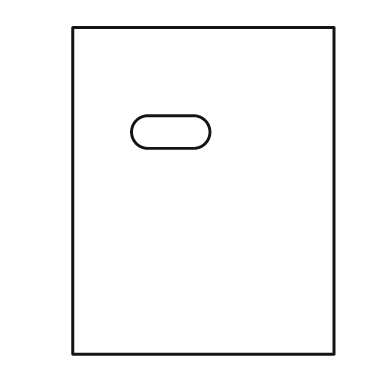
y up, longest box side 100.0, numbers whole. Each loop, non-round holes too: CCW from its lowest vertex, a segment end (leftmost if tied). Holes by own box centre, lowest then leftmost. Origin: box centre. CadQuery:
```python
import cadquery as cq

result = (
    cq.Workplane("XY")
    .moveTo(-40.0, -50.0)
    .lineTo(40.0, -50.0)
    .lineTo(40.0, 50.0)
    .lineTo(-40.0, 50.0)
    .close()
    .moveTo(-17.0, 13.0)
    .lineTo(-3.0, 13.0)
    .threePointArc((2.0, 18.0), (-3.0, 23.0))
    .lineTo(-17.0, 23.0)
    .threePointArc((-22.0, 18.0), (-17.0, 13.0))
    .close()
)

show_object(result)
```